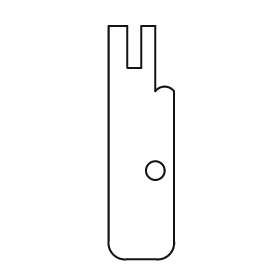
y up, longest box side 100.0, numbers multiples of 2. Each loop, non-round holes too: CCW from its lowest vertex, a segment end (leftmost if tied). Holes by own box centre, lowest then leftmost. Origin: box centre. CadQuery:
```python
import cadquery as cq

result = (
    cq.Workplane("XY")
    .moveTo(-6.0, -50.0)
    .lineTo(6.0, -50.0)
    .threePointArc((12.0, -48.0), (14.0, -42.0))
    .lineTo(14.0, 22.0)
    .threePointArc((10.0, 24.0), (6.0, 22.0))
    .lineTo(6.0, 50.0)
    .lineTo(0.0, 50.0)
    .lineTo(0.0, 32.0)
    .lineTo(-6.0, 32.0)
    .lineTo(-6.0, 50.0)
    .lineTo(-14.0, 50.0)
    .lineTo(-14.0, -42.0)
    .threePointArc((-12.0, -48.0), (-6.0, -50.0))
    .close()
    .moveTo(6.0, -12.0)
    .circle(4.0)
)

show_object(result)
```